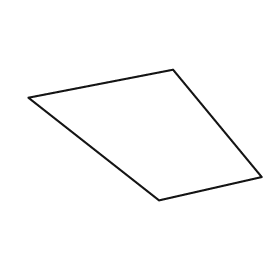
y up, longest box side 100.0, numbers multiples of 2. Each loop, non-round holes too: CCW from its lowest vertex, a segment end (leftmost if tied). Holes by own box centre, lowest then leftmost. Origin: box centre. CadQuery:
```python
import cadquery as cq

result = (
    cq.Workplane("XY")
    .moveTo(6.0, -28.0)
    .lineTo(50.0, -18.0)
    .lineTo(12.0, 28.0)
    .lineTo(-50.0, 16.0)
    .close()
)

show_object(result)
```